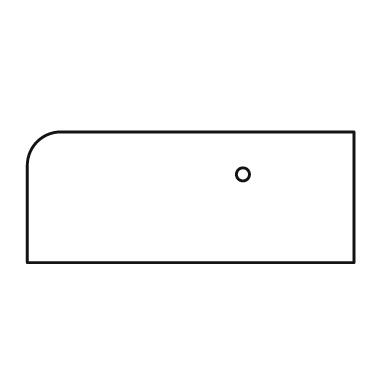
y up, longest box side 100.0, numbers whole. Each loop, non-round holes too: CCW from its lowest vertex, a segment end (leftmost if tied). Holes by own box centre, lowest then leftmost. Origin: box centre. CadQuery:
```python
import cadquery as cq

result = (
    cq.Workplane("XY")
    .moveTo(-50.0, -20.0)
    .lineTo(50.0, -20.0)
    .lineTo(50.0, 20.0)
    .lineTo(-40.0, 20.0)
    .threePointArc((-47.0, 17.0), (-50.0, 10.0))
    .close()
    .moveTo(16.0, 7.0)
    .circle(2.0)
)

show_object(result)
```